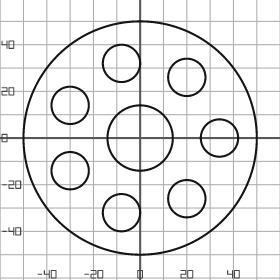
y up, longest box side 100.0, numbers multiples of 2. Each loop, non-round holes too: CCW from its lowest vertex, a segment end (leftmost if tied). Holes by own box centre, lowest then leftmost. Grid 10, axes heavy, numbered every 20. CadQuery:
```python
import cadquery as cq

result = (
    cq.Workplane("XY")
    .moveTo(0.0, 0.0)
    .circle(50.0)
    .moveTo(-8.0, -32.0)
    .circle(8.0)
    .moveTo(20.0, -26.0)
    .circle(8.0)
    .moveTo(-30.0, -14.0)
    .circle(8.0)
    .moveTo(0.0, 0.0)
    .circle(14.0)
    .moveTo(34.0, 0.0)
    .circle(8.0)
    .moveTo(-30.0, 14.0)
    .circle(8.0)
    .moveTo(20.0, 26.0)
    .circle(8.0)
    .moveTo(-8.0, 32.0)
    .circle(8.0)
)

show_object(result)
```